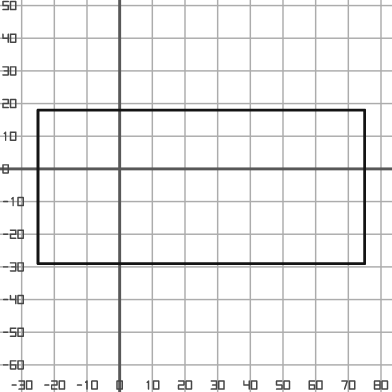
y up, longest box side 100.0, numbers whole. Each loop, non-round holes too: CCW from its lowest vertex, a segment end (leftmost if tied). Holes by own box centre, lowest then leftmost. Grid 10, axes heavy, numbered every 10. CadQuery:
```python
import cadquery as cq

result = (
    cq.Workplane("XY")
    .moveTo(-25.0, -29.0)
    .lineTo(75.0, -29.0)
    .lineTo(75.0, 18.0)
    .lineTo(-25.0, 18.0)
    .close()
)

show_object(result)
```